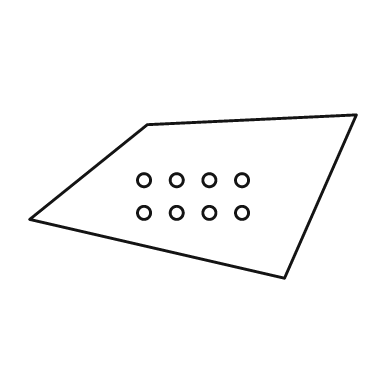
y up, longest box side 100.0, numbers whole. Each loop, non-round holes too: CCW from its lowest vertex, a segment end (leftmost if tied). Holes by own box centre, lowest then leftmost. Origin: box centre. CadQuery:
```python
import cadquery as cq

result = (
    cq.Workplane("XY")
    .moveTo(28.0, -25.0)
    .lineTo(50.0, 25.0)
    .lineTo(-14.0, 22.0)
    .lineTo(-50.0, -7.0)
    .close()
    .moveTo(-15.0, -5.0)
    .circle(2.0)
    .moveTo(-5.0, -5.0)
    .circle(2.0)
    .moveTo(5.0, -5.0)
    .circle(2.0)
    .moveTo(15.0, -5.0)
    .circle(2.0)
    .moveTo(-15.0, 5.0)
    .circle(2.0)
    .moveTo(-5.0, 5.0)
    .circle(2.0)
    .moveTo(5.0, 5.0)
    .circle(2.0)
    .moveTo(15.0, 5.0)
    .circle(2.0)
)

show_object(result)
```